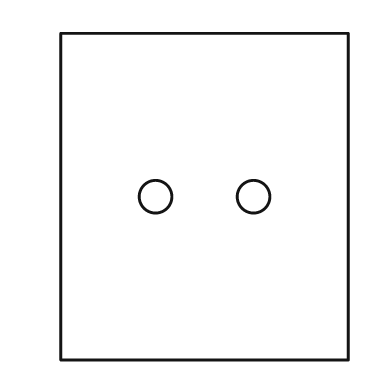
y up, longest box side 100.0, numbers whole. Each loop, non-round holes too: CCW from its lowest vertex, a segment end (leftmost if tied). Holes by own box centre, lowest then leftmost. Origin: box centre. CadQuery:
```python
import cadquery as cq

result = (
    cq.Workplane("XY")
    .moveTo(-44.0, -50.0)
    .lineTo(44.0, -50.0)
    .lineTo(44.0, 50.0)
    .lineTo(-44.0, 50.0)
    .close()
    .moveTo(-15.0, 0.0)
    .circle(5.0)
    .moveTo(15.0, 0.0)
    .circle(5.0)
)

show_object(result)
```